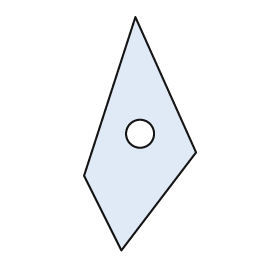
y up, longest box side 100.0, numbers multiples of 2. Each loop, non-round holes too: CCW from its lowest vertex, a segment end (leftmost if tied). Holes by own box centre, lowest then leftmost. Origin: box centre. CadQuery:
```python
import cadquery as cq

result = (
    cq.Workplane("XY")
    .moveTo(-8.0, -50.0)
    .lineTo(24.0, -8.0)
    .lineTo(-2.0, 50.0)
    .lineTo(-24.0, -18.0)
    .close()
    .moveTo(0.0, 0.0)
    .circle(6.0)
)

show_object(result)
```